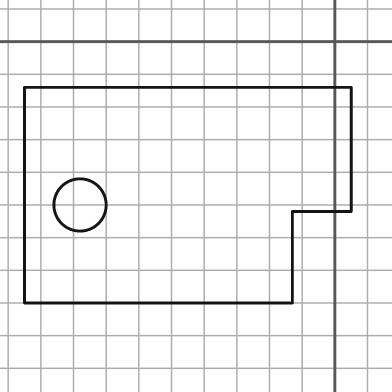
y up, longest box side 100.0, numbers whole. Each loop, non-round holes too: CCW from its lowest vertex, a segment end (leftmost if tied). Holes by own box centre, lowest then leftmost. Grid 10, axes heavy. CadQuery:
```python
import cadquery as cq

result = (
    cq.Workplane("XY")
    .moveTo(-95.0, -80.0)
    .lineTo(-13.0, -80.0)
    .lineTo(-13.0, -52.0)
    .lineTo(5.0, -52.0)
    .lineTo(5.0, -14.0)
    .lineTo(-95.0, -14.0)
    .close()
    .moveTo(-78.0, -50.0)
    .circle(8.0)
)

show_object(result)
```